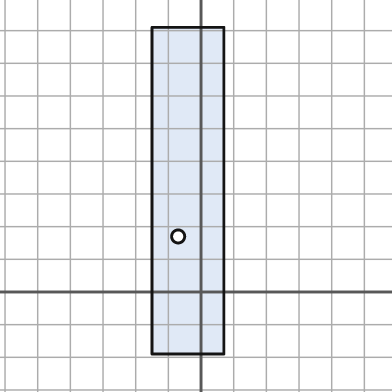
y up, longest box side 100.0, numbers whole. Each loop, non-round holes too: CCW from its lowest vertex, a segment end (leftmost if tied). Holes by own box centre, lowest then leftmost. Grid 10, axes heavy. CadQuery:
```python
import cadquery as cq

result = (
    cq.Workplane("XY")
    .moveTo(-15.0, -19.0)
    .lineTo(7.0, -19.0)
    .lineTo(7.0, 81.0)
    .lineTo(-15.0, 81.0)
    .close()
    .moveTo(-7.0, 17.0)
    .circle(2.0)
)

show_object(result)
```